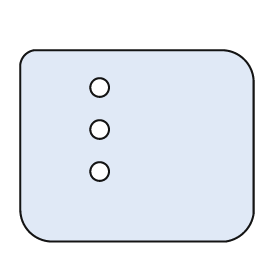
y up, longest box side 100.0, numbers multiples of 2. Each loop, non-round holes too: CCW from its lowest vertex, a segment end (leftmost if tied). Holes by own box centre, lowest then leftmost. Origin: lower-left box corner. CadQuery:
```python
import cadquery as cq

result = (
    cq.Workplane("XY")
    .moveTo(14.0, 0.0)
    .lineTo(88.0, 0.0)
    .threePointArc((96.0, 4.0), (100.0, 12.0))
    .lineTo(100.0, 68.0)
    .threePointArc((96.0, 78.0), (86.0, 82.0))
    .lineTo(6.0, 82.0)
    .threePointArc((2.0, 80.0), (0.0, 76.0))
    .lineTo(0.0, 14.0)
    .threePointArc((4.0, 4.0), (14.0, 0.0))
    .close()
    .moveTo(34.0, 30.0)
    .circle(4.0)
    .moveTo(34.0, 48.0)
    .circle(4.0)
    .moveTo(34.0, 66.0)
    .circle(4.0)
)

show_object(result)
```